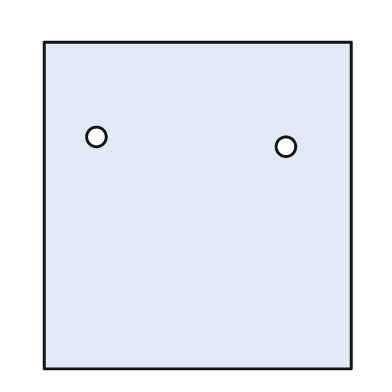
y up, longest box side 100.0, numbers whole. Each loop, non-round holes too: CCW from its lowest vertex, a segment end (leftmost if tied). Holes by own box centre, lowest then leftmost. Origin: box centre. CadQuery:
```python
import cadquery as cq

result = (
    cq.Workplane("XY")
    .moveTo(-47.0, -50.0)
    .lineTo(47.0, -50.0)
    .lineTo(47.0, 50.0)
    .lineTo(-47.0, 50.0)
    .close()
    .moveTo(27.0, 18.0)
    .circle(3.0)
    .moveTo(-31.0, 21.0)
    .circle(3.0)
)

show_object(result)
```